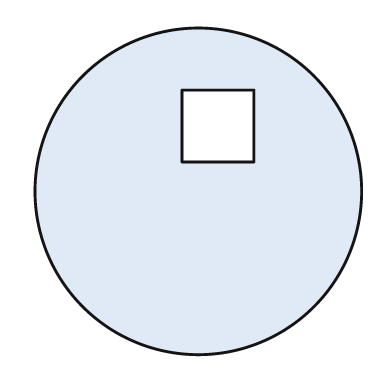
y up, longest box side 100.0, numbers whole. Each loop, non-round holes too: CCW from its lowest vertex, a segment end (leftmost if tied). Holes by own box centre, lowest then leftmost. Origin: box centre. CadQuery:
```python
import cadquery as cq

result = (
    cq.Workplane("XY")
    .moveTo(0.0, 0.0)
    .circle(50.0)
    .moveTo(-5.0, 9.0)
    .lineTo(17.0, 9.0)
    .lineTo(17.0, 31.0)
    .lineTo(-5.0, 31.0)
    .close()
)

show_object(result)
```